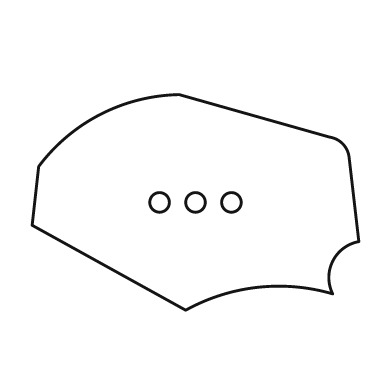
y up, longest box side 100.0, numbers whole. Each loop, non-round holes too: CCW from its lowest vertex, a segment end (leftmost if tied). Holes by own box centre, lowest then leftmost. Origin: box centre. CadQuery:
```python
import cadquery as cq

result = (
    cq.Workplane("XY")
    .moveTo(-3.0, -33.0)
    .threePointArc((19.0, -26.0), (42.0, -28.0))
    .threePointArc((42.0, -18.0), (50.0, -12.0))
    .lineTo(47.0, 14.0)
    .threePointArc((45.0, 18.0), (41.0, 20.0))
    .lineTo(-5.0, 33.0)
    .threePointArc((-29.0, 27.0), (-48.0, 11.0))
    .lineTo(-50.0, -7.0)
    .close()
    .moveTo(-11.0, 0.0)
    .circle(3.0)
    .moveTo(0.0, 0.0)
    .circle(3.0)
    .moveTo(11.0, 0.0)
    .circle(3.0)
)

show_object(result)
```